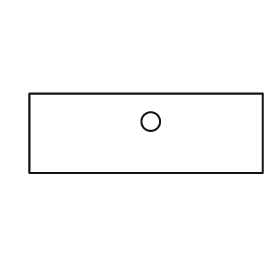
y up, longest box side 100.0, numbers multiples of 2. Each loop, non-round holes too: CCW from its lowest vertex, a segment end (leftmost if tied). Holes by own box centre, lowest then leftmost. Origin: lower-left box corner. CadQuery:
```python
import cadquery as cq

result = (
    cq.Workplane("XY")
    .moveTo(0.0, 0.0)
    .lineTo(100.0, 0.0)
    .lineTo(100.0, 34.0)
    .lineTo(0.0, 34.0)
    .close()
    .moveTo(52.0, 22.0)
    .circle(4.0)
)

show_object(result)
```